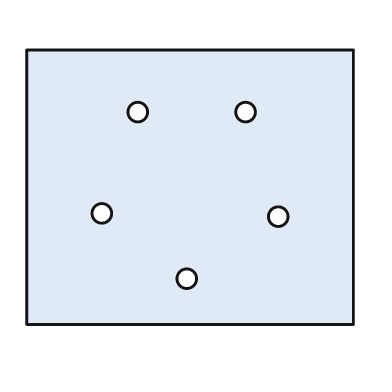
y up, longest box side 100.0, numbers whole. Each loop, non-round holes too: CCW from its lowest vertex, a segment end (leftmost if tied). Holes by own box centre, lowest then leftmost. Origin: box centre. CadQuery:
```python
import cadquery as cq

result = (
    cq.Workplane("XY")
    .moveTo(-50.0, -42.0)
    .lineTo(50.0, -42.0)
    .lineTo(50.0, 42.0)
    .lineTo(-50.0, 42.0)
    .close()
    .moveTo(-1.0, -28.0)
    .circle(3.0)
    .moveTo(27.0, -9.0)
    .circle(3.0)
    .moveTo(-27.0, -8.0)
    .circle(3.0)
    .moveTo(-16.0, 23.0)
    .circle(3.0)
    .moveTo(17.0, 23.0)
    .circle(3.0)
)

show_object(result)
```